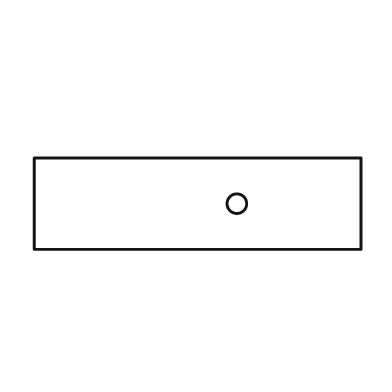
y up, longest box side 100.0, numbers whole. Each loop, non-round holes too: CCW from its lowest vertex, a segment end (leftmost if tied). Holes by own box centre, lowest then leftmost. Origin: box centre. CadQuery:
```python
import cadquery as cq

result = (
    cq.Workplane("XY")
    .moveTo(-50.0, -14.0)
    .lineTo(50.0, -14.0)
    .lineTo(50.0, 14.0)
    .lineTo(-50.0, 14.0)
    .close()
    .moveTo(12.0, 0.0)
    .circle(3.0)
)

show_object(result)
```